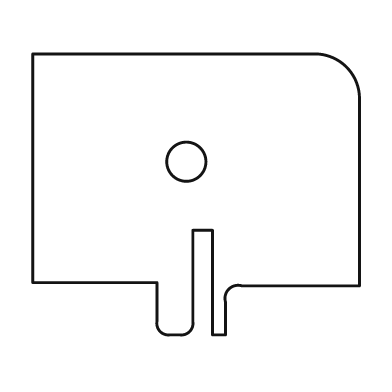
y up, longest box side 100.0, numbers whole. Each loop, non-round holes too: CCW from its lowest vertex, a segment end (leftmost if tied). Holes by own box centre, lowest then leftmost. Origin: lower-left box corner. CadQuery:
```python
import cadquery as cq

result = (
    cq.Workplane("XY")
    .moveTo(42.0, 0.0)
    .lineTo(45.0, 0.0)
    .threePointArc((48.0, 1.0), (49.0, 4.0))
    .lineTo(49.0, 32.0)
    .lineTo(55.0, 32.0)
    .lineTo(55.0, 0.0)
    .lineTo(59.0, 0.0)
    .lineTo(59.0, 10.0)
    .threePointArc((60.0, 14.0), (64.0, 15.0))
    .lineTo(100.0, 15.0)
    .lineTo(100.0, 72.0)
    .threePointArc((96.0, 82.0), (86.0, 86.0))
    .lineTo(0.0, 86.0)
    .lineTo(0.0, 16.0)
    .lineTo(38.0, 16.0)
    .lineTo(38.0, 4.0)
    .threePointArc((39.0, 1.0), (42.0, 0.0))
    .close()
    .moveTo(47.0, 53.0)
    .circle(6.0)
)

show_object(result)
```